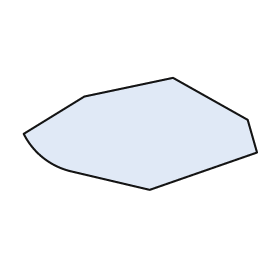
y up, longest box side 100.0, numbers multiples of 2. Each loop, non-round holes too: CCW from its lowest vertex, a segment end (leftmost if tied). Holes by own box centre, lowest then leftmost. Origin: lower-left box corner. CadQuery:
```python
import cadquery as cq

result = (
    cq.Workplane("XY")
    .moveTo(54.0, 0.0)
    .lineTo(100.0, 16.0)
    .lineTo(96.0, 30.0)
    .lineTo(64.0, 48.0)
    .lineTo(26.0, 40.0)
    .lineTo(0.0, 24.0)
    .threePointArc((8.0, 14.0), (20.0, 8.0))
    .close()
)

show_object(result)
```